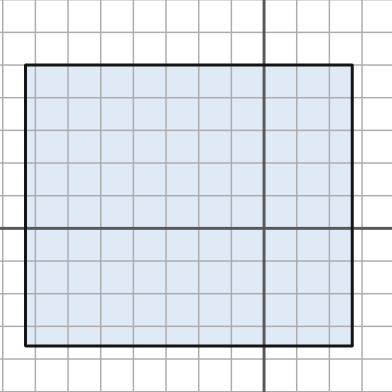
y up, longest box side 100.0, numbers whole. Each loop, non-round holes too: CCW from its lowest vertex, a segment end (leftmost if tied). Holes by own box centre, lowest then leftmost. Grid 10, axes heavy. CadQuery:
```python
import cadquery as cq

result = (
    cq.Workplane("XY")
    .moveTo(-73.0, -36.0)
    .lineTo(27.0, -36.0)
    .lineTo(27.0, 50.0)
    .lineTo(-73.0, 50.0)
    .close()
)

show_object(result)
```